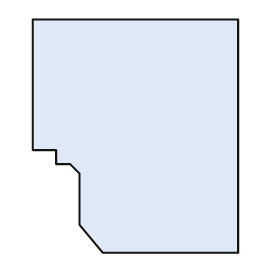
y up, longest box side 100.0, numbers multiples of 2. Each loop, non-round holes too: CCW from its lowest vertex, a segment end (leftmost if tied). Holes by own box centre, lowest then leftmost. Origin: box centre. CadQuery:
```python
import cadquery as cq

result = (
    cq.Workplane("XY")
    .moveTo(-14.0, -50.0)
    .lineTo(44.0, -50.0)
    .lineTo(44.0, 50.0)
    .lineTo(-44.0, 50.0)
    .lineTo(-44.0, -6.0)
    .lineTo(-34.0, -6.0)
    .lineTo(-34.0, -12.0)
    .lineTo(-28.0, -12.0)
    .lineTo(-24.0, -16.0)
    .lineTo(-24.0, -38.0)
    .close()
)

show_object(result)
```